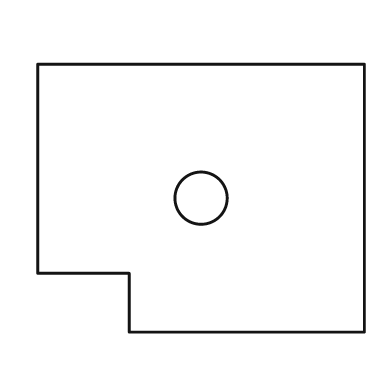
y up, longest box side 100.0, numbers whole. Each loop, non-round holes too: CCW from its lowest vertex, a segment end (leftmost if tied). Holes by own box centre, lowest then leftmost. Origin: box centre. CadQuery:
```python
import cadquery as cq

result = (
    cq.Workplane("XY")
    .moveTo(-22.0, -41.0)
    .lineTo(50.0, -41.0)
    .lineTo(50.0, 41.0)
    .lineTo(-50.0, 41.0)
    .lineTo(-50.0, -23.0)
    .lineTo(-22.0, -23.0)
    .close()
    .moveTo(0.0, 0.0)
    .circle(8.0)
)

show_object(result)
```